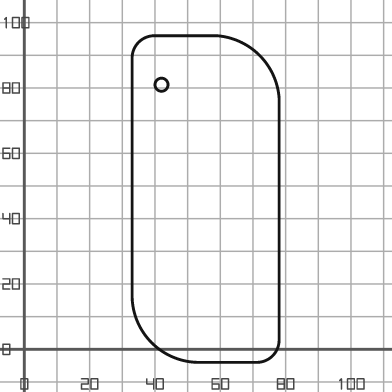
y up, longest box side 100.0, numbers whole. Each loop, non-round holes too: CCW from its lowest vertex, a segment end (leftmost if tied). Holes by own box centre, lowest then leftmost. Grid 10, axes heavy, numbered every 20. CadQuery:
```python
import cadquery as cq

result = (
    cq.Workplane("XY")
    .moveTo(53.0, -4.0)
    .lineTo(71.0, -4.0)
    .threePointArc((76.0, -2.0), (78.0, 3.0))
    .lineTo(78.0, 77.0)
    .threePointArc((72.0, 90.0), (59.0, 96.0))
    .lineTo(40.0, 96.0)
    .threePointArc((35.0, 94.0), (33.0, 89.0))
    .lineTo(33.0, 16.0)
    .threePointArc((39.0, 2.0), (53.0, -4.0))
    .close()
    .moveTo(42.0, 81.0)
    .circle(2.0)
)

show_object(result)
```